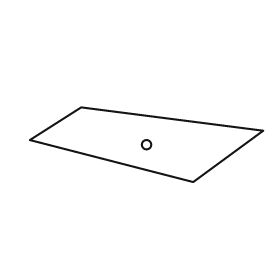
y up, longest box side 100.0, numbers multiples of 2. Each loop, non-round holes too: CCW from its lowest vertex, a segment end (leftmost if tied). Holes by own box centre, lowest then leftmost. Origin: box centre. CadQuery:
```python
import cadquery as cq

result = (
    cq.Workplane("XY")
    .moveTo(20.0, -16.0)
    .lineTo(50.0, 6.0)
    .lineTo(-28.0, 16.0)
    .lineTo(-50.0, 2.0)
    .close()
    .moveTo(0.0, 0.0)
    .circle(2.0)
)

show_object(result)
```